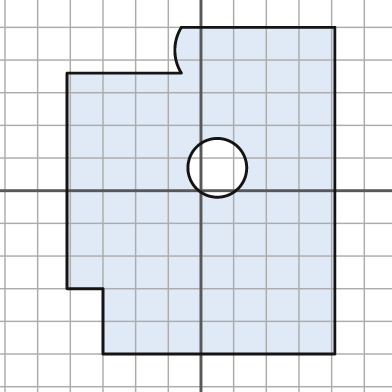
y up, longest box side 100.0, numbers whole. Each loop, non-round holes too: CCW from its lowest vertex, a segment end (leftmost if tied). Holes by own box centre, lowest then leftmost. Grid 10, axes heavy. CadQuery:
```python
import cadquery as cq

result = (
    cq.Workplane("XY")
    .moveTo(-30.0, -50.0)
    .lineTo(41.0, -50.0)
    .lineTo(41.0, 50.0)
    .lineTo(-6.0, 50.0)
    .threePointArc((-8.0, 43.0), (-6.0, 36.0))
    .lineTo(-41.0, 36.0)
    .lineTo(-41.0, -30.0)
    .lineTo(-30.0, -30.0)
    .close()
    .moveTo(5.0, 7.0)
    .circle(9.0)
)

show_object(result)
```